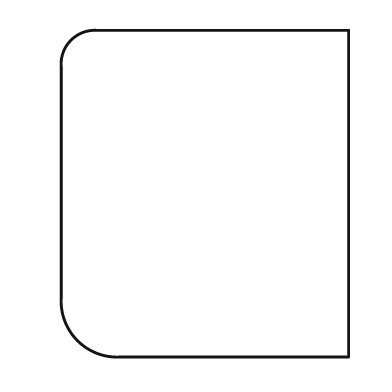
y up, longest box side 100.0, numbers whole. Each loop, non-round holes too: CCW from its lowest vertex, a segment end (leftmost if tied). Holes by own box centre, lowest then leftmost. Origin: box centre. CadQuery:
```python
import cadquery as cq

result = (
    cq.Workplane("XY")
    .moveTo(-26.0, -50.0)
    .lineTo(44.0, -50.0)
    .lineTo(44.0, 50.0)
    .lineTo(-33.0, 50.0)
    .threePointArc((-41.0, 47.0), (-44.0, 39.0))
    .lineTo(-44.0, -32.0)
    .threePointArc((-39.0, -45.0), (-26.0, -50.0))
    .close()
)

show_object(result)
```